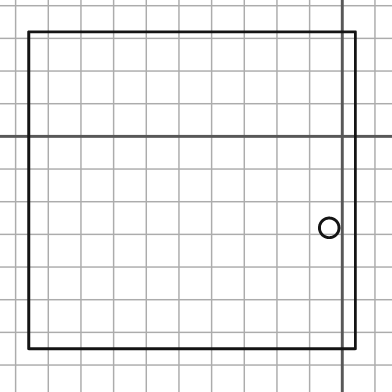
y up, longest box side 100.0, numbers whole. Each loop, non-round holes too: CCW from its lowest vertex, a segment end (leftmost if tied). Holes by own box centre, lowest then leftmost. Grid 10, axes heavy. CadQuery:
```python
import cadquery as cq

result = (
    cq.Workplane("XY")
    .moveTo(-96.0, -65.0)
    .lineTo(4.0, -65.0)
    .lineTo(4.0, 32.0)
    .lineTo(-96.0, 32.0)
    .close()
    .moveTo(-4.0, -28.0)
    .circle(3.0)
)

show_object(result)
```